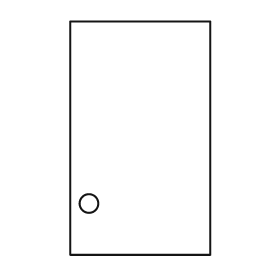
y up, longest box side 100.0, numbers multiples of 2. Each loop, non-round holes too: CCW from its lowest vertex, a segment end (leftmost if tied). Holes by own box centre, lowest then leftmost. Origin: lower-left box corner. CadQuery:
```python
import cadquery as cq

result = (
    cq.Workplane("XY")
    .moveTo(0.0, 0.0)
    .lineTo(60.0, 0.0)
    .lineTo(60.0, 100.0)
    .lineTo(0.0, 100.0)
    .close()
    .moveTo(8.0, 22.0)
    .circle(4.0)
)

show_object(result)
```